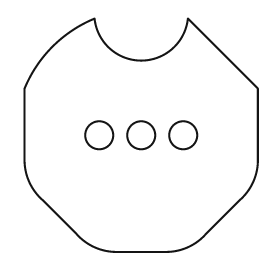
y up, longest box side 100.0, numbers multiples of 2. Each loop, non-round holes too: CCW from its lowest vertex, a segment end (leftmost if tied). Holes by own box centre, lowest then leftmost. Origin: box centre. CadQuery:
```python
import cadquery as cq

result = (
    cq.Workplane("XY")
    .moveTo(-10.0, -50.0)
    .lineTo(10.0, -50.0)
    .threePointArc((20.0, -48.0), (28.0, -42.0))
    .lineTo(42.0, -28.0)
    .threePointArc((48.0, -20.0), (50.0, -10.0))
    .lineTo(50.0, 20.0)
    .lineTo(20.0, 50.0)
    .threePointArc((0.0, 32.0), (-20.0, 50.0))
    .threePointArc((-38.0, 38.0), (-50.0, 20.0))
    .lineTo(-50.0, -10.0)
    .threePointArc((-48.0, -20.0), (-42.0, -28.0))
    .lineTo(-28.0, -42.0)
    .threePointArc((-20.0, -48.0), (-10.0, -50.0))
    .close()
    .moveTo(-18.0, 0.0)
    .circle(6.0)
    .moveTo(0.0, 0.0)
    .circle(6.0)
    .moveTo(18.0, 0.0)
    .circle(6.0)
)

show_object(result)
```